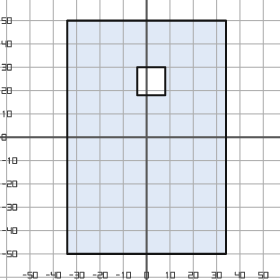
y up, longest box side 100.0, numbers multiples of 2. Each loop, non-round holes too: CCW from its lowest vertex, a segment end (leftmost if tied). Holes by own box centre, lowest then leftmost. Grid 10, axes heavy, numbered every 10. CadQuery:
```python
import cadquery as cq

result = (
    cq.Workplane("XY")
    .moveTo(-34.0, -50.0)
    .lineTo(34.0, -50.0)
    .lineTo(34.0, 50.0)
    .lineTo(-34.0, 50.0)
    .close()
    .moveTo(-4.0, 18.0)
    .lineTo(8.0, 18.0)
    .lineTo(8.0, 30.0)
    .lineTo(-4.0, 30.0)
    .close()
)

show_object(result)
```